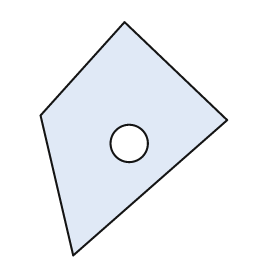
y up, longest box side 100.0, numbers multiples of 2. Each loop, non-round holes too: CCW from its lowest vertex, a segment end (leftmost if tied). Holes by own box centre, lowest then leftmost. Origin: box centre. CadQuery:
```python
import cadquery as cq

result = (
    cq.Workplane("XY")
    .moveTo(-26.0, -50.0)
    .lineTo(40.0, 8.0)
    .lineTo(-4.0, 50.0)
    .lineTo(-40.0, 10.0)
    .close()
    .moveTo(-2.0, -2.0)
    .circle(8.0)
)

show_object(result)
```